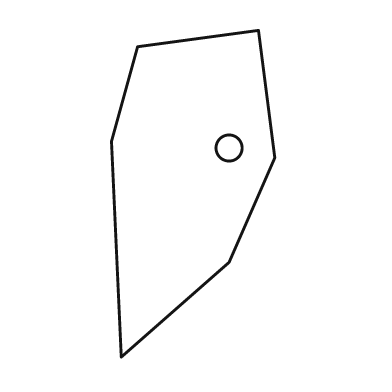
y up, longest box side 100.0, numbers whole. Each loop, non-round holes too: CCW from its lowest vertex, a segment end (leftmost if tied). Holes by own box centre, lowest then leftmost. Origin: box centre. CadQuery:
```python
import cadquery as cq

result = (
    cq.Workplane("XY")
    .moveTo(-22.0, -50.0)
    .lineTo(11.0, -21.0)
    .lineTo(25.0, 11.0)
    .lineTo(20.0, 50.0)
    .lineTo(-17.0, 45.0)
    .lineTo(-25.0, 16.0)
    .close()
    .moveTo(11.0, 14.0)
    .circle(4.0)
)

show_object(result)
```